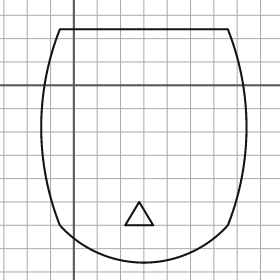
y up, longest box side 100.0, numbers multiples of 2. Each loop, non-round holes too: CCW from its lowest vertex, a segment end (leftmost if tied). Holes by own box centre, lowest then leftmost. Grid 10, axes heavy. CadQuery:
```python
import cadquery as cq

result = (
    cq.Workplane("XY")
    .moveTo(-6.0, -60.0)
    .threePointArc((30.0, -76.0), (66.0, -60.0))
    .threePointArc((74.0, -18.0), (66.0, 24.0))
    .lineTo(-6.0, 24.0)
    .threePointArc((-14.0, -18.0), (-6.0, -60.0))
    .close()
    .moveTo(22.0, -60.0)
    .lineTo(34.0, -60.0)
    .lineTo(28.0, -50.0)
    .close()
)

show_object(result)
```